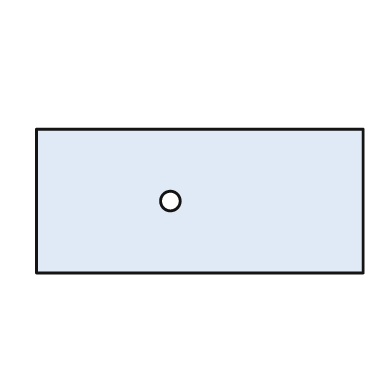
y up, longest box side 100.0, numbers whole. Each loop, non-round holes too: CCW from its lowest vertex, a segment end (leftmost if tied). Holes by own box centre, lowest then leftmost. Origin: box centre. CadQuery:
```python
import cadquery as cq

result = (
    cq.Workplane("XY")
    .moveTo(-50.0, -22.0)
    .lineTo(50.0, -22.0)
    .lineTo(50.0, 22.0)
    .lineTo(-50.0, 22.0)
    .close()
    .moveTo(-9.0, 0.0)
    .circle(3.0)
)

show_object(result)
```